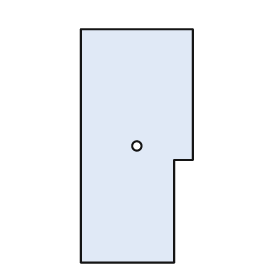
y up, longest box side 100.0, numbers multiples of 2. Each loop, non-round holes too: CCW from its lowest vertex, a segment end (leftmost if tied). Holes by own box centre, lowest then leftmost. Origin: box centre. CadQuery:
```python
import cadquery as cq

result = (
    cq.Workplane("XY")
    .moveTo(-24.0, -50.0)
    .lineTo(16.0, -50.0)
    .lineTo(16.0, -6.0)
    .lineTo(24.0, -6.0)
    .lineTo(24.0, 50.0)
    .lineTo(-24.0, 50.0)
    .close()
    .moveTo(0.0, 0.0)
    .circle(2.0)
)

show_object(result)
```